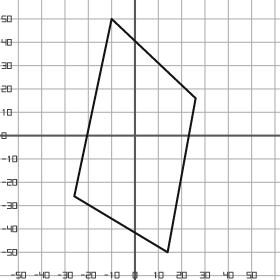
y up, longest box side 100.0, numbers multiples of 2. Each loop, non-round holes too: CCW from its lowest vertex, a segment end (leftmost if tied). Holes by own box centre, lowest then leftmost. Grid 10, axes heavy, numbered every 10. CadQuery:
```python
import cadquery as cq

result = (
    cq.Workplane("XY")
    .moveTo(14.0, -50.0)
    .lineTo(26.0, 16.0)
    .lineTo(-10.0, 50.0)
    .lineTo(-26.0, -26.0)
    .close()
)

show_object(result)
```